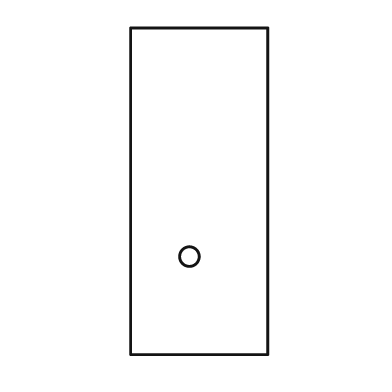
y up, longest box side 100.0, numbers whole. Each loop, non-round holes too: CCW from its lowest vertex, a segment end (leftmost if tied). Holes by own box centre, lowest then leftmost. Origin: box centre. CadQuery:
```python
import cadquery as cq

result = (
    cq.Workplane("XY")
    .moveTo(-21.0, -50.0)
    .lineTo(21.0, -50.0)
    .lineTo(21.0, 50.0)
    .lineTo(-21.0, 50.0)
    .close()
    .moveTo(-3.0, -20.0)
    .circle(3.0)
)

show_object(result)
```